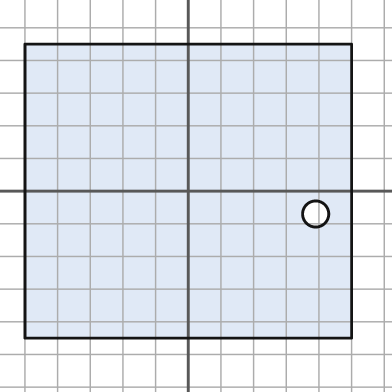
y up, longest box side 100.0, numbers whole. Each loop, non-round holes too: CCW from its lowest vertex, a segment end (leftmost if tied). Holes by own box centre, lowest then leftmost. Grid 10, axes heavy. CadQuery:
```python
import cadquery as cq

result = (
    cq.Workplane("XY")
    .moveTo(-50.0, -45.0)
    .lineTo(50.0, -45.0)
    .lineTo(50.0, 45.0)
    .lineTo(-50.0, 45.0)
    .close()
    .moveTo(39.0, -7.0)
    .circle(4.0)
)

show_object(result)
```